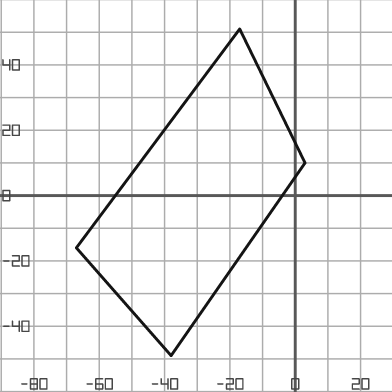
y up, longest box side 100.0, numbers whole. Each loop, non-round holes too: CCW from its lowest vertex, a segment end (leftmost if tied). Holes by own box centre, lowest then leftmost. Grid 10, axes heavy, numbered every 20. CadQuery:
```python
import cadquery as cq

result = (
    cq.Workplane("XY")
    .moveTo(-38.0, -49.0)
    .lineTo(3.0, 10.0)
    .lineTo(-17.0, 51.0)
    .lineTo(-67.0, -16.0)
    .close()
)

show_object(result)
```